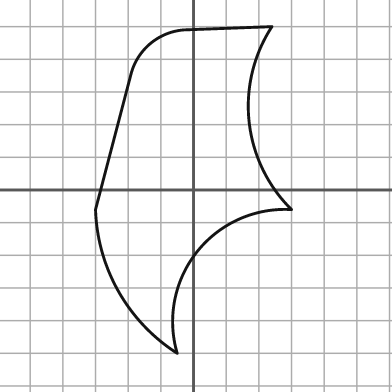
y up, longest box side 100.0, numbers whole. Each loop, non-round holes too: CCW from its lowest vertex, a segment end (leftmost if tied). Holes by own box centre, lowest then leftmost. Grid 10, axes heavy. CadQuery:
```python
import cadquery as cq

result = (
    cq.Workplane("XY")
    .moveTo(-5.0, -50.0)
    .threePointArc((1.0, -19.0), (30.0, -6.0))
    .threePointArc((17.0, 21.0), (24.0, 50.0))
    .lineTo(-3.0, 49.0)
    .threePointArc((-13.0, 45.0), (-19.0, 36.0))
    .lineTo(-30.0, -6.0)
    .threePointArc((-23.0, -31.0), (-5.0, -50.0))
    .close()
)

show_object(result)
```